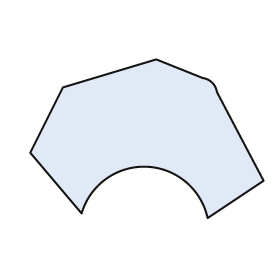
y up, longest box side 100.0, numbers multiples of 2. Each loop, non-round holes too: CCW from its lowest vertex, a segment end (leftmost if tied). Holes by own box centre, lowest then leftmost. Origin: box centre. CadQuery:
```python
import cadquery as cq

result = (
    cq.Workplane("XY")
    .moveTo(26.0, -34.0)
    .lineTo(50.0, -18.0)
    .lineTo(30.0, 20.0)
    .threePointArc((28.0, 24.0), (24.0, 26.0))
    .lineTo(4.0, 34.0)
    .lineTo(-36.0, 22.0)
    .lineTo(-50.0, -6.0)
    .lineTo(-28.0, -32.0)
    .threePointArc((0.0, -12.0), (26.0, -34.0))
    .close()
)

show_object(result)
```